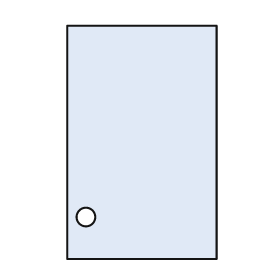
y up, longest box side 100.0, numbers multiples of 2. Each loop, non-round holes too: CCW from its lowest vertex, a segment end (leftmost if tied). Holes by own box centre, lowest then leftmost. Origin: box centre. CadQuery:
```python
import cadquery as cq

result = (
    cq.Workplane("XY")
    .moveTo(-32.0, -50.0)
    .lineTo(32.0, -50.0)
    .lineTo(32.0, 50.0)
    .lineTo(-32.0, 50.0)
    .close()
    .moveTo(-24.0, -32.0)
    .circle(4.0)
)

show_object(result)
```